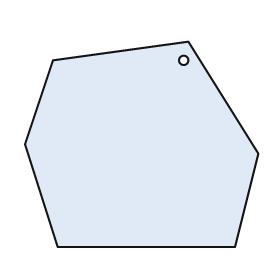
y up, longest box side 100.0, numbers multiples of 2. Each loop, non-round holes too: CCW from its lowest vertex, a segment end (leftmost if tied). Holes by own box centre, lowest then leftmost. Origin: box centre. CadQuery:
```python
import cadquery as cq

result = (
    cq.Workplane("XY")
    .moveTo(-36.0, -44.0)
    .lineTo(40.0, -44.0)
    .lineTo(50.0, -4.0)
    .lineTo(20.0, 44.0)
    .lineTo(-38.0, 36.0)
    .lineTo(-50.0, 0.0)
    .close()
    .moveTo(18.0, 36.0)
    .circle(2.0)
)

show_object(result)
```